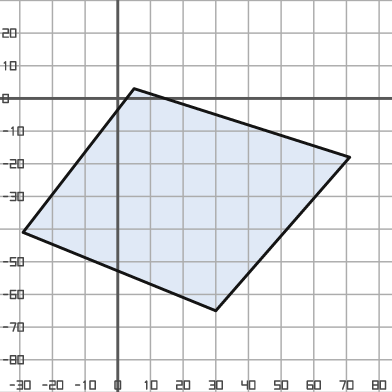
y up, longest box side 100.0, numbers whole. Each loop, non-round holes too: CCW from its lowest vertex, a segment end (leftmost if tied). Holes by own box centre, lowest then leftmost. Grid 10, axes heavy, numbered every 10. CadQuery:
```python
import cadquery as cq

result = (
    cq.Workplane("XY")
    .moveTo(30.0, -65.0)
    .lineTo(71.0, -18.0)
    .lineTo(5.0, 3.0)
    .lineTo(-29.0, -41.0)
    .close()
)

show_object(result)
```